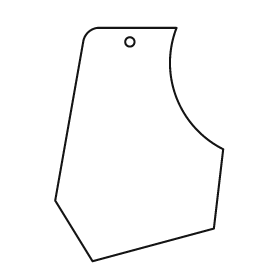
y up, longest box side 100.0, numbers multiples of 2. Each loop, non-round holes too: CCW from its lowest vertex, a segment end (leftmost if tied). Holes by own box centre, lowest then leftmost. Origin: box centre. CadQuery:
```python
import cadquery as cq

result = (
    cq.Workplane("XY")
    .moveTo(-20.0, -50.0)
    .lineTo(32.0, -36.0)
    .lineTo(36.0, -2.0)
    .threePointArc((16.0, 20.0), (16.0, 50.0))
    .lineTo(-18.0, 50.0)
    .threePointArc((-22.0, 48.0), (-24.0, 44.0))
    .lineTo(-36.0, -24.0)
    .close()
    .moveTo(-4.0, 44.0)
    .circle(2.0)
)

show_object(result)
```